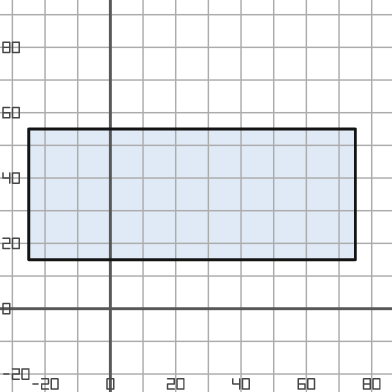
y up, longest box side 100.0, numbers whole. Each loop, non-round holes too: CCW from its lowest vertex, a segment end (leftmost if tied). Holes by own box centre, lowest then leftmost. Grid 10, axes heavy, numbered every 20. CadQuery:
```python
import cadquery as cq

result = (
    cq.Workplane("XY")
    .moveTo(-25.0, 15.0)
    .lineTo(75.0, 15.0)
    .lineTo(75.0, 55.0)
    .lineTo(-25.0, 55.0)
    .close()
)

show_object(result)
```